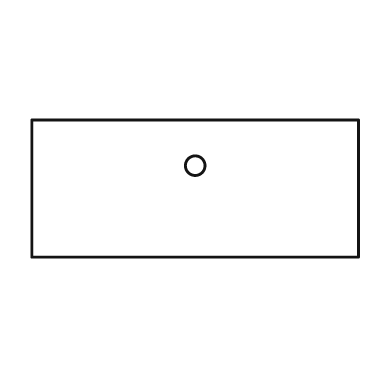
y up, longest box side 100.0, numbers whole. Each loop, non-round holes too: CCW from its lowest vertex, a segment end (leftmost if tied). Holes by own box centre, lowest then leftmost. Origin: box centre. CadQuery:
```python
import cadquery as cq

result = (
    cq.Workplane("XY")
    .moveTo(-50.0, -21.0)
    .lineTo(50.0, -21.0)
    .lineTo(50.0, 21.0)
    .lineTo(-50.0, 21.0)
    .close()
    .moveTo(0.0, 7.0)
    .circle(3.0)
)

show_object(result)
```